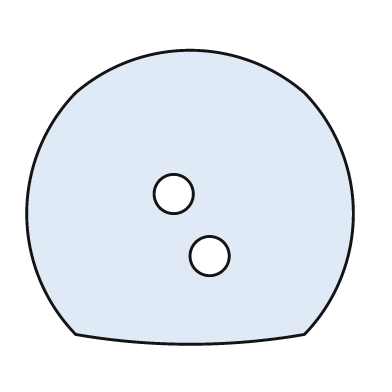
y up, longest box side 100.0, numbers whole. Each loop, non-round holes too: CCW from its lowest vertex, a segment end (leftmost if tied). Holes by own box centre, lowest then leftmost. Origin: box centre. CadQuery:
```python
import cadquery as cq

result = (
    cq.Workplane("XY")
    .moveTo(-35.0, -42.0)
    .threePointArc((0.0, -45.0), (35.0, -42.0))
    .threePointArc((50.0, -5.0), (35.0, 32.0))
    .threePointArc((0.0, 45.0), (-35.0, 32.0))
    .threePointArc((-50.0, -5.0), (-35.0, -42.0))
    .close()
    .moveTo(6.0, -18.0)
    .circle(6.0)
    .moveTo(-5.0, 1.0)
    .circle(6.0)
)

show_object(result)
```